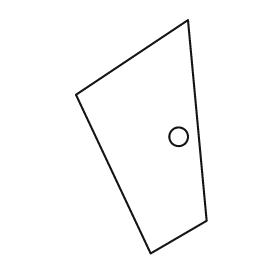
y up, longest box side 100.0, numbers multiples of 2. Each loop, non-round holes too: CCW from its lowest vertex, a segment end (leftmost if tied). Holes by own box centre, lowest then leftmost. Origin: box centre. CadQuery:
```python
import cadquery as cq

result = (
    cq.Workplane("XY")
    .moveTo(4.0, -50.0)
    .lineTo(28.0, -36.0)
    .lineTo(20.0, 50.0)
    .lineTo(-28.0, 18.0)
    .close()
    .moveTo(16.0, 0.0)
    .circle(4.0)
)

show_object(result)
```